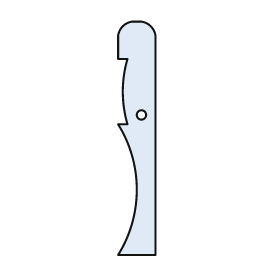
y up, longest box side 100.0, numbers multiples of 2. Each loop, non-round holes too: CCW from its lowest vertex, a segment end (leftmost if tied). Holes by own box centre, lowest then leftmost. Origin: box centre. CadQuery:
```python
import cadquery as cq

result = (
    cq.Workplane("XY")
    .moveTo(-8.0, -50.0)
    .lineTo(8.0, -50.0)
    .lineTo(8.0, 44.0)
    .threePointArc((6.0, 48.0), (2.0, 50.0))
    .lineTo(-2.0, 50.0)
    .threePointArc((-6.0, 48.0), (-8.0, 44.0))
    .lineTo(-8.0, 34.0)
    .lineTo(-4.0, 34.0)
    .threePointArc((-6.0, 20.0), (-4.0, 6.0))
    .lineTo(-8.0, 6.0)
    .threePointArc((0.0, -22.0), (-8.0, -50.0))
    .close()
    .moveTo(2.0, 10.0)
    .circle(2.0)
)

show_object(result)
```